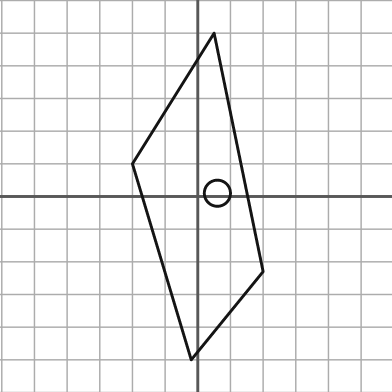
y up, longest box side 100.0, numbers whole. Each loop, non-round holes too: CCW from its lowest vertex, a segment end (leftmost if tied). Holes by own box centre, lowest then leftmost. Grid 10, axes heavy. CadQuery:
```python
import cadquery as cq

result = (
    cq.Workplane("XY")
    .moveTo(-2.0, -50.0)
    .lineTo(20.0, -23.0)
    .lineTo(5.0, 50.0)
    .lineTo(-20.0, 10.0)
    .close()
    .moveTo(6.0, 1.0)
    .circle(4.0)
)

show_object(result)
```